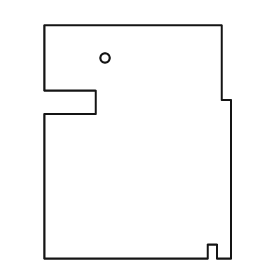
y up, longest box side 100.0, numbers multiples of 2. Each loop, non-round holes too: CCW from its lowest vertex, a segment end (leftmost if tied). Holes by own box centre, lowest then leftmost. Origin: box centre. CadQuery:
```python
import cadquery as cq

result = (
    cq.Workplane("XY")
    .moveTo(-40.0, -50.0)
    .lineTo(30.0, -50.0)
    .lineTo(30.0, -44.0)
    .lineTo(34.0, -44.0)
    .lineTo(34.0, -50.0)
    .lineTo(40.0, -50.0)
    .lineTo(40.0, 18.0)
    .lineTo(36.0, 18.0)
    .lineTo(36.0, 50.0)
    .lineTo(-40.0, 50.0)
    .lineTo(-40.0, 22.0)
    .lineTo(-18.0, 22.0)
    .lineTo(-18.0, 12.0)
    .lineTo(-40.0, 12.0)
    .close()
    .moveTo(-14.0, 36.0)
    .circle(2.0)
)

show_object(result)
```